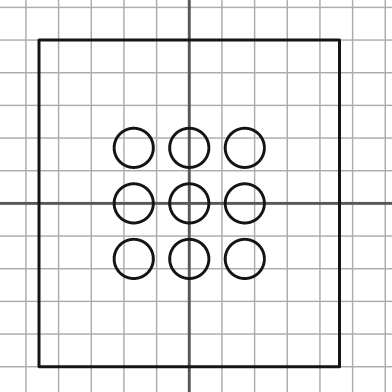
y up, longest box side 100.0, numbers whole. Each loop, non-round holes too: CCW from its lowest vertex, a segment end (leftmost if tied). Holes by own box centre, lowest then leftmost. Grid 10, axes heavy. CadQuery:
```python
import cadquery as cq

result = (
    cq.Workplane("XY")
    .moveTo(-46.0, -50.0)
    .lineTo(46.0, -50.0)
    .lineTo(46.0, 50.0)
    .lineTo(-46.0, 50.0)
    .close()
    .moveTo(-17.0, -17.0)
    .circle(6.0)
    .moveTo(0.0, -17.0)
    .circle(6.0)
    .moveTo(17.0, -17.0)
    .circle(6.0)
    .moveTo(-17.0, 0.0)
    .circle(6.0)
    .moveTo(0.0, 0.0)
    .circle(6.0)
    .moveTo(17.0, 0.0)
    .circle(6.0)
    .moveTo(-17.0, 17.0)
    .circle(6.0)
    .moveTo(0.0, 17.0)
    .circle(6.0)
    .moveTo(17.0, 17.0)
    .circle(6.0)
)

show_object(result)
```